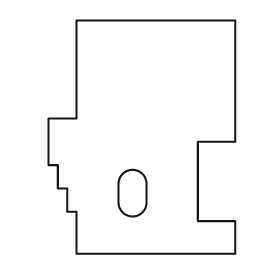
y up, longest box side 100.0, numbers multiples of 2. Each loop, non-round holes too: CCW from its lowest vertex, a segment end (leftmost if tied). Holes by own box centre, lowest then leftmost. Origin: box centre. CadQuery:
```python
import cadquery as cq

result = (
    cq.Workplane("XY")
    .moveTo(-28.0, -50.0)
    .lineTo(40.0, -50.0)
    .lineTo(40.0, -36.0)
    .lineTo(24.0, -36.0)
    .lineTo(24.0, -2.0)
    .lineTo(40.0, -2.0)
    .lineTo(40.0, 50.0)
    .lineTo(-28.0, 50.0)
    .lineTo(-28.0, 8.0)
    .lineTo(-40.0, 8.0)
    .lineTo(-40.0, -12.0)
    .lineTo(-36.0, -12.0)
    .lineTo(-36.0, -22.0)
    .lineTo(-32.0, -22.0)
    .lineTo(-32.0, -32.0)
    .lineTo(-28.0, -32.0)
    .close()
    .moveTo(-10.0, -28.0)
    .threePointArc((-4.0, -34.0), (2.0, -28.0))
    .lineTo(2.0, -20.0)
    .threePointArc((-4.0, -14.0), (-10.0, -20.0))
    .close()
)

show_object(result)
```